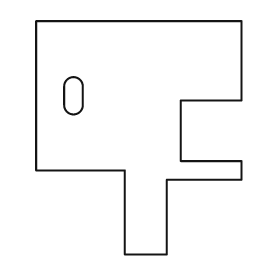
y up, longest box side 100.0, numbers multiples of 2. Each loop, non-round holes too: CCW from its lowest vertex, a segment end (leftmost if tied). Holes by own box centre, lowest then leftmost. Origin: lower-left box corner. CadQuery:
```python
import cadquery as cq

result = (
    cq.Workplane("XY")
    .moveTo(38.0, 0.0)
    .lineTo(56.0, 0.0)
    .lineTo(56.0, 32.0)
    .lineTo(88.0, 32.0)
    .lineTo(88.0, 40.0)
    .lineTo(62.0, 40.0)
    .lineTo(62.0, 66.0)
    .lineTo(88.0, 66.0)
    .lineTo(88.0, 100.0)
    .lineTo(0.0, 100.0)
    .lineTo(0.0, 36.0)
    .lineTo(38.0, 36.0)
    .close()
    .moveTo(12.0, 64.0)
    .threePointArc((16.0, 60.0), (20.0, 64.0))
    .lineTo(20.0, 72.0)
    .threePointArc((16.0, 76.0), (12.0, 72.0))
    .close()
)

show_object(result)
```